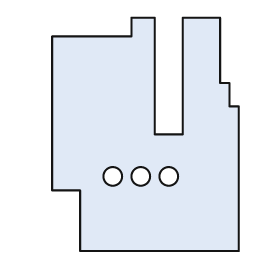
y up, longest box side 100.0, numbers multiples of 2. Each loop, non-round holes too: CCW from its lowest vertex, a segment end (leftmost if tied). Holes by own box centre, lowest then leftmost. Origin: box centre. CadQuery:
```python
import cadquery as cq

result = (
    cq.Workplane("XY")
    .moveTo(-28.0, -50.0)
    .lineTo(40.0, -50.0)
    .lineTo(40.0, 12.0)
    .lineTo(36.0, 12.0)
    .lineTo(36.0, 22.0)
    .lineTo(32.0, 22.0)
    .lineTo(32.0, 50.0)
    .lineTo(16.0, 50.0)
    .lineTo(16.0, 0.0)
    .lineTo(4.0, 0.0)
    .lineTo(4.0, 50.0)
    .lineTo(-6.0, 50.0)
    .lineTo(-6.0, 42.0)
    .lineTo(-40.0, 42.0)
    .lineTo(-40.0, -24.0)
    .lineTo(-28.0, -24.0)
    .close()
    .moveTo(-14.0, -18.0)
    .circle(4.0)
    .moveTo(-2.0, -18.0)
    .circle(4.0)
    .moveTo(10.0, -18.0)
    .circle(4.0)
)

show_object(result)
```